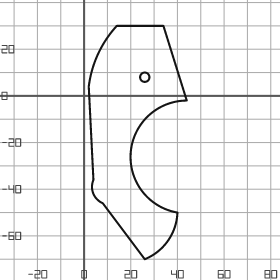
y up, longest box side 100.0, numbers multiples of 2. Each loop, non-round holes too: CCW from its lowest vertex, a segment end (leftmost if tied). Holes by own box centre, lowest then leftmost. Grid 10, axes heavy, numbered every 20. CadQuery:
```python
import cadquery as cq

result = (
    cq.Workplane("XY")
    .moveTo(26.0, -70.0)
    .threePointArc((36.0, -62.0), (40.0, -50.0))
    .threePointArc((20.0, -24.0), (44.0, -2.0))
    .lineTo(34.0, 30.0)
    .lineTo(14.0, 30.0)
    .threePointArc((6.0, 18.0), (2.0, 4.0))
    .lineTo(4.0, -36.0)
    .threePointArc((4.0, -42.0), (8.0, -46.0))
    .close()
    .moveTo(26.0, 8.0)
    .circle(2.0)
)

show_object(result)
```